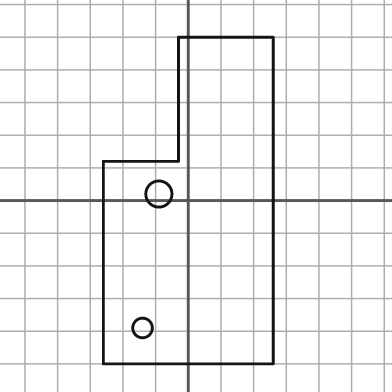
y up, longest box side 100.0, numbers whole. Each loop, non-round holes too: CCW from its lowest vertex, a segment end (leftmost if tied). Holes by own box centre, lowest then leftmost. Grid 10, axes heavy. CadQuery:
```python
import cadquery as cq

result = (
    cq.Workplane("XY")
    .moveTo(-26.0, -50.0)
    .lineTo(26.0, -50.0)
    .lineTo(26.0, 50.0)
    .lineTo(-3.0, 50.0)
    .lineTo(-3.0, 12.0)
    .lineTo(-26.0, 12.0)
    .close()
    .moveTo(-14.0, -39.0)
    .circle(3.0)
    .moveTo(-9.0, 2.0)
    .circle(4.0)
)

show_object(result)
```